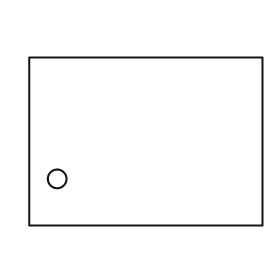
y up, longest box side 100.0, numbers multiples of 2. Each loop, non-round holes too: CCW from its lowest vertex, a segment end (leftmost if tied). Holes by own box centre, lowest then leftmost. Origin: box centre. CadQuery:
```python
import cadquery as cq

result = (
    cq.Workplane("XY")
    .moveTo(-50.0, -36.0)
    .lineTo(50.0, -36.0)
    .lineTo(50.0, 36.0)
    .lineTo(-50.0, 36.0)
    .close()
    .moveTo(-38.0, -16.0)
    .circle(4.0)
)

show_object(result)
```